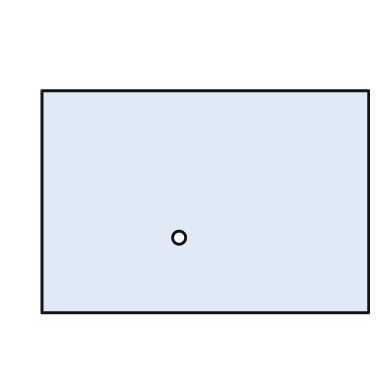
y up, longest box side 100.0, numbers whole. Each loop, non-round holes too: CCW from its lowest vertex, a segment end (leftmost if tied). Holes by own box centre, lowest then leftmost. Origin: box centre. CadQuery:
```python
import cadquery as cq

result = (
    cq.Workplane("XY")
    .moveTo(-50.0, -34.0)
    .lineTo(50.0, -34.0)
    .lineTo(50.0, 34.0)
    .lineTo(-50.0, 34.0)
    .close()
    .moveTo(-8.0, -11.0)
    .circle(2.0)
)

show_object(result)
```